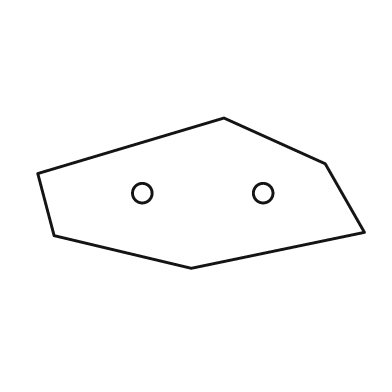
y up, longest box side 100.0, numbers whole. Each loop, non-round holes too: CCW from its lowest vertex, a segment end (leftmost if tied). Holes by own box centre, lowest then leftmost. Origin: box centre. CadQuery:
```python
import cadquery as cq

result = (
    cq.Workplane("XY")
    .moveTo(-3.0, -23.0)
    .lineTo(50.0, -12.0)
    .lineTo(38.0, 9.0)
    .lineTo(7.0, 23.0)
    .lineTo(-50.0, 6.0)
    .lineTo(-45.0, -13.0)
    .close()
    .moveTo(-18.0, 0.0)
    .circle(3.0)
    .moveTo(19.0, 0.0)
    .circle(3.0)
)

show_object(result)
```